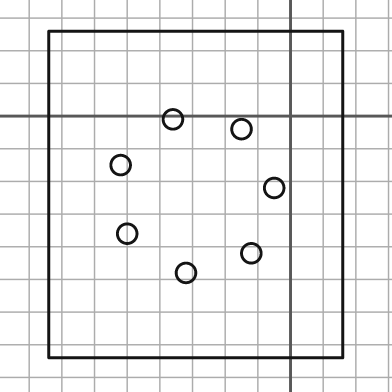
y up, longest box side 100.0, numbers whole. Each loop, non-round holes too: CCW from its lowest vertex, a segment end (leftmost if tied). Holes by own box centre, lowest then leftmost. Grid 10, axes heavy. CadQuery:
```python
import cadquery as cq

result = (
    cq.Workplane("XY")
    .moveTo(-74.0, -74.0)
    .lineTo(16.0, -74.0)
    .lineTo(16.0, 26.0)
    .lineTo(-74.0, 26.0)
    .close()
    .moveTo(-32.0, -48.0)
    .circle(3.0)
    .moveTo(-12.0, -42.0)
    .circle(3.0)
    .moveTo(-50.0, -36.0)
    .circle(3.0)
    .moveTo(-5.0, -22.0)
    .circle(3.0)
    .moveTo(-52.0, -15.0)
    .circle(3.0)
    .moveTo(-15.0, -4.0)
    .circle(3.0)
    .moveTo(-36.0, -1.0)
    .circle(3.0)
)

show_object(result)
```